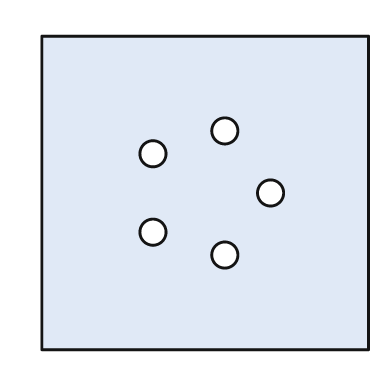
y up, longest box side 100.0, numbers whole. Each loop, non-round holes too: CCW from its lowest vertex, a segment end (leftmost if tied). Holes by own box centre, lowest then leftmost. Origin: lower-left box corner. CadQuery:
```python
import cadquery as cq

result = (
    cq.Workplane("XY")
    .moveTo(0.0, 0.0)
    .lineTo(100.0, 0.0)
    .lineTo(100.0, 96.0)
    .lineTo(0.0, 96.0)
    .close()
    .moveTo(56.0, 29.0)
    .circle(4.0)
    .moveTo(34.0, 36.0)
    .circle(4.0)
    .moveTo(70.0, 48.0)
    .circle(4.0)
    .moveTo(34.0, 60.0)
    .circle(4.0)
    .moveTo(56.0, 67.0)
    .circle(4.0)
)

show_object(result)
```